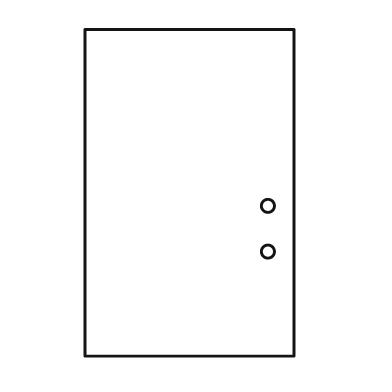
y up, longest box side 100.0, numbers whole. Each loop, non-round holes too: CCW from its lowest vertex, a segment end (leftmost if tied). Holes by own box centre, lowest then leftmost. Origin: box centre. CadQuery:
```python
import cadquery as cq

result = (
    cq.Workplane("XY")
    .moveTo(-32.0, -50.0)
    .lineTo(32.0, -50.0)
    .lineTo(32.0, 50.0)
    .lineTo(-32.0, 50.0)
    .close()
    .moveTo(24.0, -18.0)
    .circle(2.0)
    .moveTo(24.0, -4.0)
    .circle(2.0)
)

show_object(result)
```